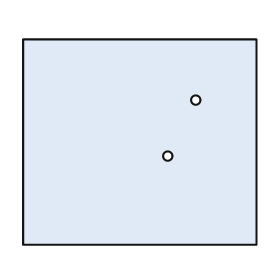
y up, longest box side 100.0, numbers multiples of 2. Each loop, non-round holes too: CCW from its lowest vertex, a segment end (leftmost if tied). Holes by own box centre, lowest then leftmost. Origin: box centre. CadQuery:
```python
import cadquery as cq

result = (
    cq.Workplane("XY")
    .moveTo(-50.0, -44.0)
    .lineTo(50.0, -44.0)
    .lineTo(50.0, 44.0)
    .lineTo(-50.0, 44.0)
    .close()
    .moveTo(12.0, -6.0)
    .circle(2.0)
    .moveTo(24.0, 18.0)
    .circle(2.0)
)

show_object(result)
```